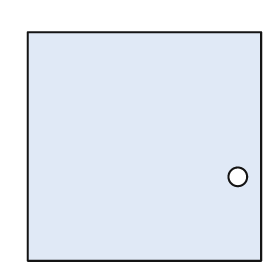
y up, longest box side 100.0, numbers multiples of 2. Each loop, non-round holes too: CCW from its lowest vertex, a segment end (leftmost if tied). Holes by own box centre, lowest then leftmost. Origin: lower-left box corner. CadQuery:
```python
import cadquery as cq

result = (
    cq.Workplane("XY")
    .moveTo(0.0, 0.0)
    .lineTo(100.0, 0.0)
    .lineTo(100.0, 98.0)
    .lineTo(0.0, 98.0)
    .close()
    .moveTo(90.0, 36.0)
    .circle(4.0)
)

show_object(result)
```